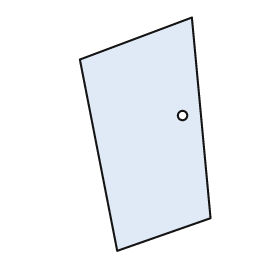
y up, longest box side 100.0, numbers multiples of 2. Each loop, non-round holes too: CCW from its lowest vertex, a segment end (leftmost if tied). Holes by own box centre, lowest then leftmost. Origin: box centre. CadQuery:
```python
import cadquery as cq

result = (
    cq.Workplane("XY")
    .moveTo(-12.0, -50.0)
    .lineTo(28.0, -36.0)
    .lineTo(20.0, 50.0)
    .lineTo(-28.0, 32.0)
    .close()
    .moveTo(16.0, 8.0)
    .circle(2.0)
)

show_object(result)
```